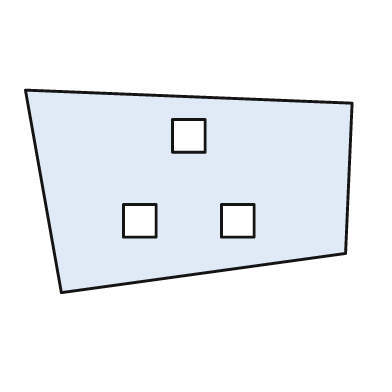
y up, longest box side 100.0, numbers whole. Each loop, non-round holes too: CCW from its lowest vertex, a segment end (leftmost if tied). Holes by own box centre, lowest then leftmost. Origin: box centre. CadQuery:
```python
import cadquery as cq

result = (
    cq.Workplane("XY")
    .moveTo(-39.0, -31.0)
    .lineTo(48.0, -19.0)
    .lineTo(50.0, 27.0)
    .lineTo(-50.0, 31.0)
    .close()
    .moveTo(-20.0, -14.0)
    .lineTo(-10.0, -14.0)
    .lineTo(-10.0, -4.0)
    .lineTo(-20.0, -4.0)
    .close()
    .moveTo(10.0, -14.0)
    .lineTo(20.0, -14.0)
    .lineTo(20.0, -4.0)
    .lineTo(10.0, -4.0)
    .close()
    .moveTo(-5.0, 12.0)
    .lineTo(5.0, 12.0)
    .lineTo(5.0, 22.0)
    .lineTo(-5.0, 22.0)
    .close()
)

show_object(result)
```